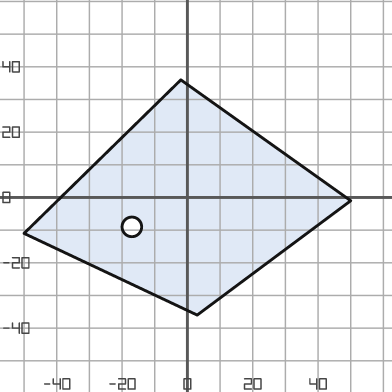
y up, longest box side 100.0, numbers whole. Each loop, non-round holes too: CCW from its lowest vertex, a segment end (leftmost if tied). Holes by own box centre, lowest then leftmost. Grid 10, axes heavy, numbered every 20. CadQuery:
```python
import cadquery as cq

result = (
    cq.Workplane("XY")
    .moveTo(3.0, -36.0)
    .lineTo(50.0, -1.0)
    .lineTo(-2.0, 36.0)
    .lineTo(-50.0, -11.0)
    .close()
    .moveTo(-17.0, -9.0)
    .circle(3.0)
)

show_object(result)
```